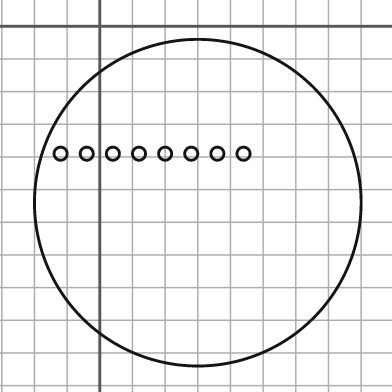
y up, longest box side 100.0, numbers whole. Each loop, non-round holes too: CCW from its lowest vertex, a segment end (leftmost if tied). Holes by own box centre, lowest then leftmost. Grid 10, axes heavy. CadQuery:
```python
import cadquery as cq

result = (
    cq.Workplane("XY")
    .moveTo(30.0, -54.0)
    .circle(50.0)
    .moveTo(-12.0, -39.0)
    .circle(2.0)
    .moveTo(-4.0, -39.0)
    .circle(2.0)
    .moveTo(4.0, -39.0)
    .circle(2.0)
    .moveTo(12.0, -39.0)
    .circle(2.0)
    .moveTo(20.0, -39.0)
    .circle(2.0)
    .moveTo(28.0, -39.0)
    .circle(2.0)
    .moveTo(36.0, -39.0)
    .circle(2.0)
    .moveTo(44.0, -39.0)
    .circle(2.0)
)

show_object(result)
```